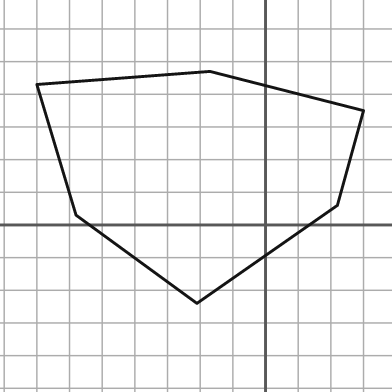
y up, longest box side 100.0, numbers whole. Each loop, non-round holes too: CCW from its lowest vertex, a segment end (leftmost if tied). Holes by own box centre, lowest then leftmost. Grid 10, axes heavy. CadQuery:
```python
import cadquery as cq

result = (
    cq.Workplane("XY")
    .moveTo(-21.0, -24.0)
    .lineTo(22.0, 6.0)
    .lineTo(30.0, 35.0)
    .lineTo(-17.0, 47.0)
    .lineTo(-70.0, 43.0)
    .lineTo(-58.0, 3.0)
    .close()
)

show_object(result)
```